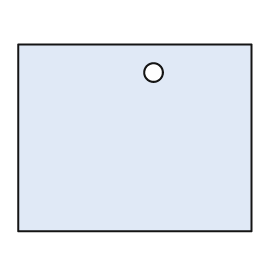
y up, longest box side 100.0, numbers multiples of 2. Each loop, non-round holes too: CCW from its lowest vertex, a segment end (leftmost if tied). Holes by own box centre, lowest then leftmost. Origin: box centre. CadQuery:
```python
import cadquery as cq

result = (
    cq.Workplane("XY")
    .moveTo(-50.0, -40.0)
    .lineTo(50.0, -40.0)
    .lineTo(50.0, 40.0)
    .lineTo(-50.0, 40.0)
    .close()
    .moveTo(8.0, 28.0)
    .circle(4.0)
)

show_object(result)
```